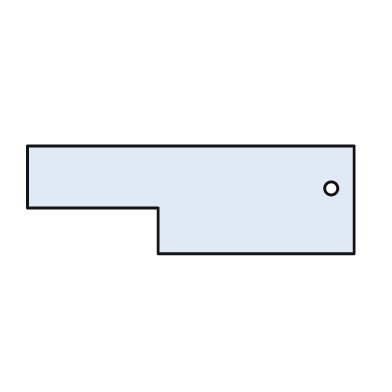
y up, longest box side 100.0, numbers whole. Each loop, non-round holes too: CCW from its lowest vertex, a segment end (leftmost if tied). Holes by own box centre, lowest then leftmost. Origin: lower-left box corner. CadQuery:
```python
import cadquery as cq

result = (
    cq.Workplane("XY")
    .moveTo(40.0, 0.0)
    .lineTo(100.0, 0.0)
    .lineTo(100.0, 33.0)
    .lineTo(0.0, 33.0)
    .lineTo(0.0, 14.0)
    .lineTo(40.0, 14.0)
    .close()
    .moveTo(93.0, 20.0)
    .circle(2.0)
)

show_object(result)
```